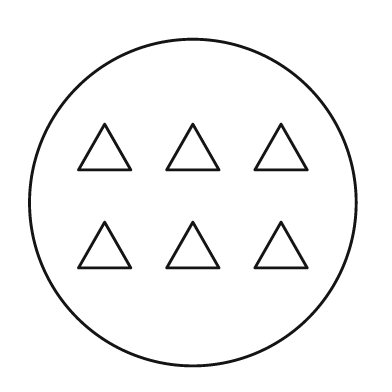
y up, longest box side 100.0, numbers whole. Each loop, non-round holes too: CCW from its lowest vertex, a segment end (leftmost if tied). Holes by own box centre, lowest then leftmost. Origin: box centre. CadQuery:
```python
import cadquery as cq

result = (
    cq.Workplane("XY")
    .moveTo(0.0, 0.0)
    .circle(50.0)
    .moveTo(-35.0, -20.0)
    .lineTo(-19.0, -20.0)
    .lineTo(-27.0, -6.0)
    .close()
    .moveTo(-8.0, -20.0)
    .lineTo(8.0, -20.0)
    .lineTo(0.0, -6.0)
    .close()
    .moveTo(19.0, -20.0)
    .lineTo(35.0, -20.0)
    .lineTo(27.0, -6.0)
    .close()
    .moveTo(-35.0, 10.0)
    .lineTo(-19.0, 10.0)
    .lineTo(-27.0, 24.0)
    .close()
    .moveTo(-8.0, 10.0)
    .lineTo(8.0, 10.0)
    .lineTo(0.0, 24.0)
    .close()
    .moveTo(19.0, 10.0)
    .lineTo(35.0, 10.0)
    .lineTo(27.0, 24.0)
    .close()
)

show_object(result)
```